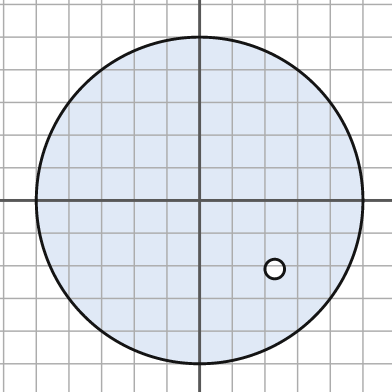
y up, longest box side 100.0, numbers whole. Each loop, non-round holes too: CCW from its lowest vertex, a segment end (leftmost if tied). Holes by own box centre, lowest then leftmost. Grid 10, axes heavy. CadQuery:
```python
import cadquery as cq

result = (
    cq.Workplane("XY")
    .moveTo(0.0, 0.0)
    .circle(50.0)
    .moveTo(23.0, -21.0)
    .circle(3.0)
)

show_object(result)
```